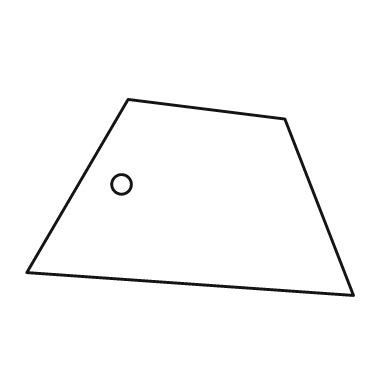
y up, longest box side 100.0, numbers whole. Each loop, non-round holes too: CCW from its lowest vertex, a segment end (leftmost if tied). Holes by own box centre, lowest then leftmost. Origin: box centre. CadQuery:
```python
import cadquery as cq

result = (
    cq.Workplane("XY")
    .moveTo(50.0, -30.0)
    .lineTo(29.0, 24.0)
    .lineTo(-19.0, 30.0)
    .lineTo(-50.0, -23.0)
    .close()
    .moveTo(-21.0, 4.0)
    .circle(3.0)
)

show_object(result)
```